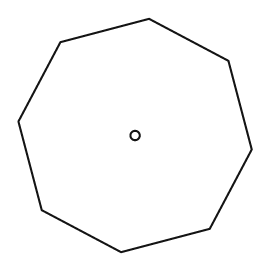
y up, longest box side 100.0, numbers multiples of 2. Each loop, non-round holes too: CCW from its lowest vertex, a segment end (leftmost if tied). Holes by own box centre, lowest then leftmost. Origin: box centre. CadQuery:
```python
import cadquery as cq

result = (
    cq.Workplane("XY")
    .moveTo(-6.0, -50.0)
    .lineTo(32.0, -40.0)
    .lineTo(50.0, -6.0)
    .lineTo(40.0, 32.0)
    .lineTo(6.0, 50.0)
    .lineTo(-32.0, 40.0)
    .lineTo(-50.0, 6.0)
    .lineTo(-40.0, -32.0)
    .close()
    .moveTo(0.0, 0.0)
    .circle(2.0)
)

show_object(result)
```